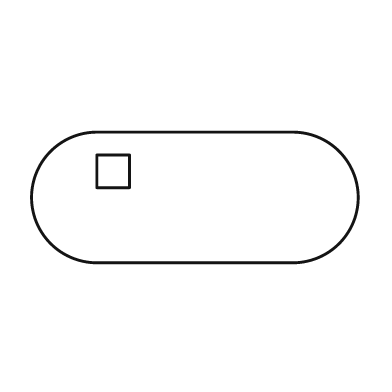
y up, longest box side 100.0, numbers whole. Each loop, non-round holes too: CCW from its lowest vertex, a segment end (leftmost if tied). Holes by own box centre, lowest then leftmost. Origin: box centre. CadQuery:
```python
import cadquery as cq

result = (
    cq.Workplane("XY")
    .moveTo(-30.0, -20.0)
    .lineTo(30.0, -20.0)
    .threePointArc((50.0, 0.0), (30.0, 20.0))
    .lineTo(-30.0, 20.0)
    .threePointArc((-50.0, 0.0), (-30.0, -20.0))
    .close()
    .moveTo(-30.0, 3.0)
    .lineTo(-20.0, 3.0)
    .lineTo(-20.0, 13.0)
    .lineTo(-30.0, 13.0)
    .close()
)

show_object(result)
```